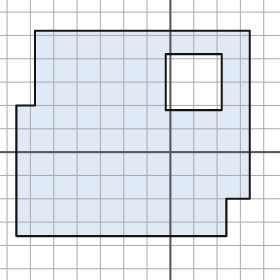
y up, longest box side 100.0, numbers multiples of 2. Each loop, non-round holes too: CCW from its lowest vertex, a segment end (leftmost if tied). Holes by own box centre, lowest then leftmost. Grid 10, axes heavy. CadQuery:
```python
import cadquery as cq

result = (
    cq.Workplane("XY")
    .moveTo(-66.0, -36.0)
    .lineTo(24.0, -36.0)
    .lineTo(24.0, -20.0)
    .lineTo(34.0, -20.0)
    .lineTo(34.0, 52.0)
    .lineTo(-58.0, 52.0)
    .lineTo(-58.0, 20.0)
    .lineTo(-66.0, 20.0)
    .close()
    .moveTo(-2.0, 18.0)
    .lineTo(22.0, 18.0)
    .lineTo(22.0, 42.0)
    .lineTo(-2.0, 42.0)
    .close()
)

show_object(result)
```